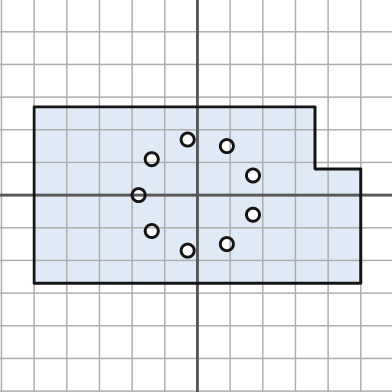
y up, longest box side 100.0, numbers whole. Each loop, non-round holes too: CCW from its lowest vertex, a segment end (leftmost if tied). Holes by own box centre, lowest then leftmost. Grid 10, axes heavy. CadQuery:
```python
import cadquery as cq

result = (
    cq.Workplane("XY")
    .moveTo(-50.0, -27.0)
    .lineTo(50.0, -27.0)
    .lineTo(50.0, 8.0)
    .lineTo(36.0, 8.0)
    .lineTo(36.0, 27.0)
    .lineTo(-50.0, 27.0)
    .close()
    .moveTo(-3.0, -17.0)
    .circle(2.0)
    .moveTo(9.0, -15.0)
    .circle(2.0)
    .moveTo(-14.0, -11.0)
    .circle(2.0)
    .moveTo(17.0, -6.0)
    .circle(2.0)
    .moveTo(-18.0, 0.0)
    .circle(2.0)
    .moveTo(17.0, 6.0)
    .circle(2.0)
    .moveTo(-14.0, 11.0)
    .circle(2.0)
    .moveTo(9.0, 15.0)
    .circle(2.0)
    .moveTo(-3.0, 17.0)
    .circle(2.0)
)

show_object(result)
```